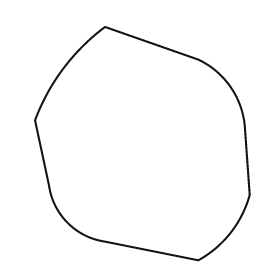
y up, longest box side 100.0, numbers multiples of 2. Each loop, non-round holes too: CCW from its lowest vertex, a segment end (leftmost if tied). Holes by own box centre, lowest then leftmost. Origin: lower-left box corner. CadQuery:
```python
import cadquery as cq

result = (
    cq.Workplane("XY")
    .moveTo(70.0, 0.0)
    .threePointArc((84.0, 12.0), (92.0, 28.0))
    .lineTo(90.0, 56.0)
    .threePointArc((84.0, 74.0), (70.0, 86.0))
    .lineTo(30.0, 100.0)
    .threePointArc((12.0, 82.0), (0.0, 60.0))
    .lineTo(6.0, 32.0)
    .threePointArc((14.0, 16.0), (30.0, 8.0))
    .close()
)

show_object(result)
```